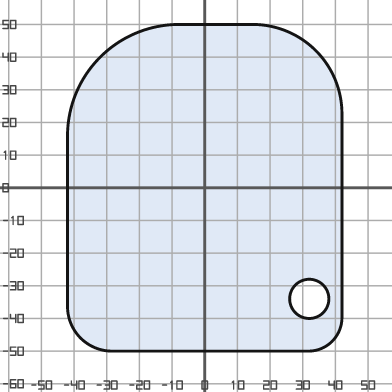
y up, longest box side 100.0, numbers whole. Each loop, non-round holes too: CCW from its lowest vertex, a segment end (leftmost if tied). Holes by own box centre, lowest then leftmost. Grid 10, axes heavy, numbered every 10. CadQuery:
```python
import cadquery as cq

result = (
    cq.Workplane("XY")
    .moveTo(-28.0, -50.0)
    .lineTo(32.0, -50.0)
    .threePointArc((39.0, -47.0), (42.0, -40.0))
    .lineTo(42.0, 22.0)
    .threePointArc((34.0, 42.0), (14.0, 50.0))
    .lineTo(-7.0, 50.0)
    .threePointArc((-32.0, 40.0), (-42.0, 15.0))
    .lineTo(-42.0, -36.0)
    .threePointArc((-38.0, -46.0), (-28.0, -50.0))
    .close()
    .moveTo(32.0, -34.0)
    .circle(6.0)
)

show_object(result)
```